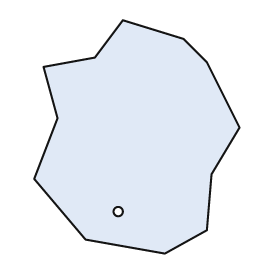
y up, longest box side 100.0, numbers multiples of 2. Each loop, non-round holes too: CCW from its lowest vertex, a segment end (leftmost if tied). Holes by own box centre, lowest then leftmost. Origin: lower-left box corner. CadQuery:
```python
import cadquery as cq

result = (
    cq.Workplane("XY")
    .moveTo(56.0, 0.0)
    .lineTo(74.0, 10.0)
    .lineTo(76.0, 34.0)
    .lineTo(88.0, 54.0)
    .lineTo(74.0, 82.0)
    .lineTo(64.0, 92.0)
    .lineTo(38.0, 100.0)
    .lineTo(26.0, 84.0)
    .lineTo(4.0, 80.0)
    .lineTo(10.0, 58.0)
    .lineTo(0.0, 32.0)
    .lineTo(22.0, 6.0)
    .close()
    .moveTo(36.0, 18.0)
    .circle(2.0)
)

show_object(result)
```